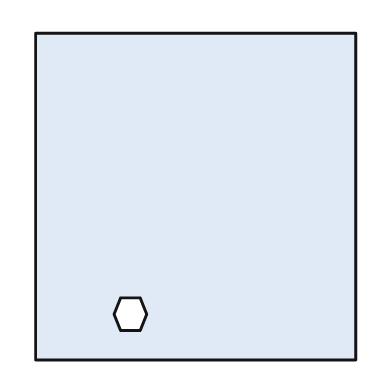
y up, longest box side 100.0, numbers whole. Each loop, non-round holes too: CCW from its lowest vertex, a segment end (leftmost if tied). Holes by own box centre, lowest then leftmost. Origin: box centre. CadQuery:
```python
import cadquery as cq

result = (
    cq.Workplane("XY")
    .moveTo(-49.0, -50.0)
    .lineTo(49.0, -50.0)
    .lineTo(49.0, 50.0)
    .lineTo(-49.0, 50.0)
    .close()
    .moveTo(-23.0, -41.0)
    .lineTo(-17.0, -41.0)
    .lineTo(-15.0, -36.0)
    .lineTo(-17.0, -31.0)
    .lineTo(-23.0, -31.0)
    .lineTo(-25.0, -36.0)
    .close()
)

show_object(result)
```